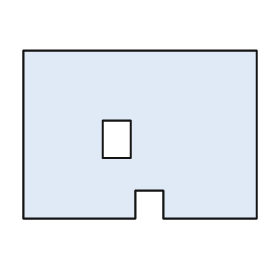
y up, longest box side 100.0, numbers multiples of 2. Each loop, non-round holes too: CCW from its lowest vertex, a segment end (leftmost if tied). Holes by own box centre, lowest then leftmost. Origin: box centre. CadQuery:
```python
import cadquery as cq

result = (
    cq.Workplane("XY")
    .moveTo(-50.0, -36.0)
    .lineTo(-2.0, -36.0)
    .lineTo(-2.0, -24.0)
    .lineTo(10.0, -24.0)
    .lineTo(10.0, -36.0)
    .lineTo(50.0, -36.0)
    .lineTo(50.0, 36.0)
    .lineTo(-50.0, 36.0)
    .close()
    .moveTo(-16.0, -10.0)
    .lineTo(-4.0, -10.0)
    .lineTo(-4.0, 6.0)
    .lineTo(-16.0, 6.0)
    .close()
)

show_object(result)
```